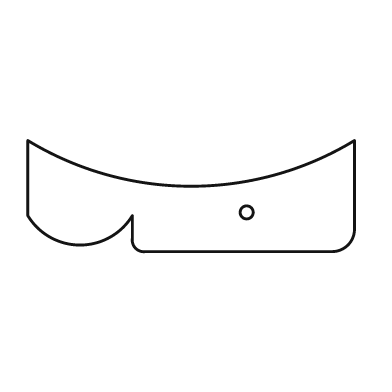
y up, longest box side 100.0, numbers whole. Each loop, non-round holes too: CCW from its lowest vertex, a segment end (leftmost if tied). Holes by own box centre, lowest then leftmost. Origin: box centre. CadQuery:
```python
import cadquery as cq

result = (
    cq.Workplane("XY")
    .moveTo(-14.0, -17.0)
    .lineTo(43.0, -17.0)
    .threePointArc((48.0, -15.0), (50.0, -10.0))
    .lineTo(50.0, 17.0)
    .threePointArc((0.0, 3.0), (-50.0, 17.0))
    .lineTo(-50.0, -6.0)
    .threePointArc((-34.0, -15.0), (-18.0, -6.0))
    .lineTo(-18.0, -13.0)
    .threePointArc((-17.0, -16.0), (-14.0, -17.0))
    .close()
    .moveTo(17.0, -5.0)
    .circle(2.0)
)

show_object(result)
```